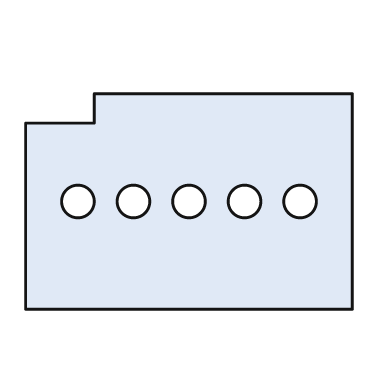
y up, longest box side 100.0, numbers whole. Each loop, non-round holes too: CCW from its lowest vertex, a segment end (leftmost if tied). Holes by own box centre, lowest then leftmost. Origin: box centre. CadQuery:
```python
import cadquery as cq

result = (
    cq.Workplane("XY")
    .moveTo(-50.0, -33.0)
    .lineTo(50.0, -33.0)
    .lineTo(50.0, 33.0)
    .lineTo(-29.0, 33.0)
    .lineTo(-29.0, 24.0)
    .lineTo(-50.0, 24.0)
    .close()
    .moveTo(-34.0, 0.0)
    .circle(5.0)
    .moveTo(-17.0, 0.0)
    .circle(5.0)
    .moveTo(0.0, 0.0)
    .circle(5.0)
    .moveTo(17.0, 0.0)
    .circle(5.0)
    .moveTo(34.0, 0.0)
    .circle(5.0)
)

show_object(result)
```